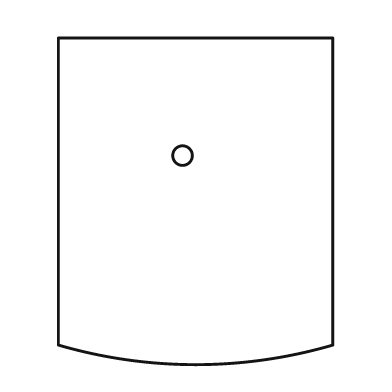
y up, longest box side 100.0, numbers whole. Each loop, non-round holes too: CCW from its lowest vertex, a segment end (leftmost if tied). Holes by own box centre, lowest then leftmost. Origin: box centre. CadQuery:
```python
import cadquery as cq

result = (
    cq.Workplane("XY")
    .moveTo(-42.0, -44.0)
    .threePointArc((0.0, -50.0), (42.0, -44.0))
    .lineTo(42.0, 50.0)
    .lineTo(-42.0, 50.0)
    .close()
    .moveTo(-4.0, 14.0)
    .circle(3.0)
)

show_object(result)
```